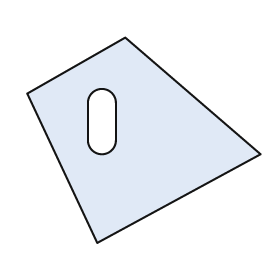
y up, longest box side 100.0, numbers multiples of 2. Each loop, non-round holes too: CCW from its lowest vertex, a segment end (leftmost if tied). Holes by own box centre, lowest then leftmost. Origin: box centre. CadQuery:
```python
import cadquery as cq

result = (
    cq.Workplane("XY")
    .moveTo(-20.0, -44.0)
    .lineTo(50.0, -6.0)
    .lineTo(-8.0, 44.0)
    .lineTo(-50.0, 20.0)
    .close()
    .moveTo(-24.0, 0.0)
    .threePointArc((-18.0, -6.0), (-12.0, 0.0))
    .lineTo(-12.0, 16.0)
    .threePointArc((-18.0, 22.0), (-24.0, 16.0))
    .close()
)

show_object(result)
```